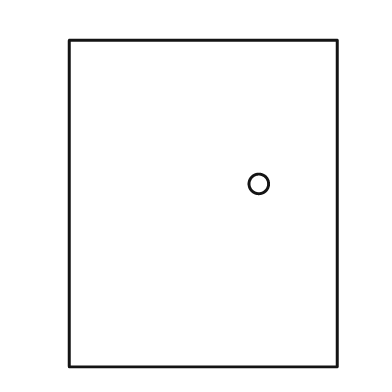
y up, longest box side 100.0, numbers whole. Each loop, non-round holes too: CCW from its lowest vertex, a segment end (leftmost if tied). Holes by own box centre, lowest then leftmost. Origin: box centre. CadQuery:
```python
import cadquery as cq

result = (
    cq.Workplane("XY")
    .moveTo(-41.0, -50.0)
    .lineTo(41.0, -50.0)
    .lineTo(41.0, 50.0)
    .lineTo(-41.0, 50.0)
    .close()
    .moveTo(17.0, 6.0)
    .circle(3.0)
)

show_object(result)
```